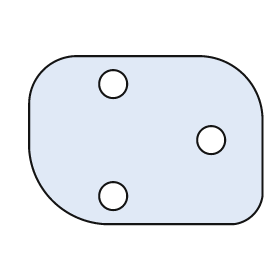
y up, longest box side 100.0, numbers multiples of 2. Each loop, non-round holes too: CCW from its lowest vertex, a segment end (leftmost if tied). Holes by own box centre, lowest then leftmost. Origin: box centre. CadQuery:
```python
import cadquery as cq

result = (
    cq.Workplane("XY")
    .moveTo(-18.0, -36.0)
    .lineTo(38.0, -36.0)
    .threePointArc((46.0, -32.0), (50.0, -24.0))
    .lineTo(50.0, 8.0)
    .threePointArc((42.0, 28.0), (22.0, 36.0))
    .lineTo(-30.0, 36.0)
    .threePointArc((-44.0, 30.0), (-50.0, 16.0))
    .lineTo(-50.0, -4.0)
    .threePointArc((-40.0, -26.0), (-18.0, -36.0))
    .close()
    .moveTo(-14.0, -24.0)
    .circle(6.0)
    .moveTo(28.0, 0.0)
    .circle(6.0)
    .moveTo(-14.0, 24.0)
    .circle(6.0)
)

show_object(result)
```